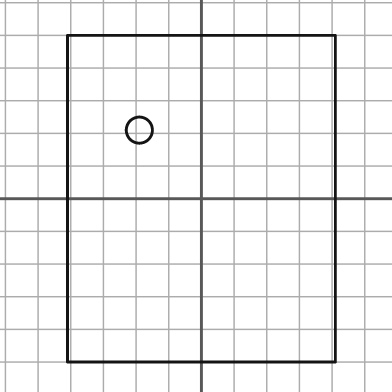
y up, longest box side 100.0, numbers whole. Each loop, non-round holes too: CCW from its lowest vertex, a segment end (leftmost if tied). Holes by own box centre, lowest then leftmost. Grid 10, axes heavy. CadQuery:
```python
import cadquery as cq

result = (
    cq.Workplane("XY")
    .moveTo(-41.0, -50.0)
    .lineTo(41.0, -50.0)
    .lineTo(41.0, 50.0)
    .lineTo(-41.0, 50.0)
    .close()
    .moveTo(-19.0, 21.0)
    .circle(4.0)
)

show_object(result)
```